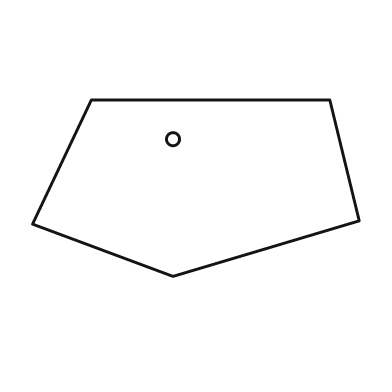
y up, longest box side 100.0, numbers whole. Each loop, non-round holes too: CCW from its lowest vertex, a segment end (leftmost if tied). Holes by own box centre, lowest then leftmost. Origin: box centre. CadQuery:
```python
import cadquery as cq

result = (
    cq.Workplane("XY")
    .moveTo(-7.0, -27.0)
    .lineTo(50.0, -10.0)
    .lineTo(41.0, 27.0)
    .lineTo(-32.0, 27.0)
    .lineTo(-50.0, -11.0)
    .close()
    .moveTo(-7.0, 15.0)
    .circle(2.0)
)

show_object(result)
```